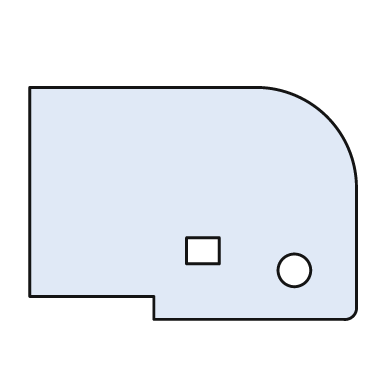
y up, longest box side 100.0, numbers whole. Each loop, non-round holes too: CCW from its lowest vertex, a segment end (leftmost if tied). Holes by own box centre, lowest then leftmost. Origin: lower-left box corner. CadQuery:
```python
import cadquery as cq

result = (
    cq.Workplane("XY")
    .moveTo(38.0, 0.0)
    .lineTo(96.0, 0.0)
    .threePointArc((99.0, 1.0), (100.0, 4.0))
    .lineTo(100.0, 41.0)
    .threePointArc((91.0, 62.0), (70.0, 71.0))
    .lineTo(0.0, 71.0)
    .lineTo(0.0, 7.0)
    .lineTo(38.0, 7.0)
    .close()
    .moveTo(81.0, 15.0)
    .circle(5.0)
    .moveTo(48.0, 17.0)
    .lineTo(58.0, 17.0)
    .lineTo(58.0, 25.0)
    .lineTo(48.0, 25.0)
    .close()
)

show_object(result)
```